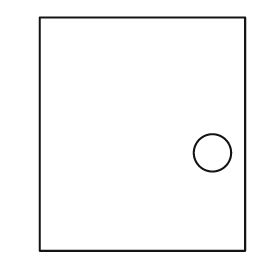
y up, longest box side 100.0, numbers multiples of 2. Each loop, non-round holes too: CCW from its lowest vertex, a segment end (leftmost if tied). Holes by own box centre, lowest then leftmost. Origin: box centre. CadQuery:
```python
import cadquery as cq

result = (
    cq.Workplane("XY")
    .moveTo(-44.0, -50.0)
    .lineTo(44.0, -50.0)
    .lineTo(44.0, 50.0)
    .lineTo(-44.0, 50.0)
    .close()
    .moveTo(30.0, -8.0)
    .circle(8.0)
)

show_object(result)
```